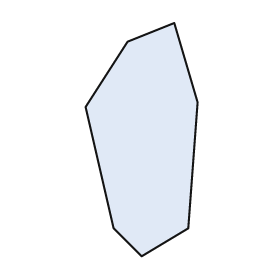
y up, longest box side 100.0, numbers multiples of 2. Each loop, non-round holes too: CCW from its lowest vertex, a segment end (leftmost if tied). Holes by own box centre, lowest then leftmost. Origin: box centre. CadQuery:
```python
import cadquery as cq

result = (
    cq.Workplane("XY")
    .moveTo(0.0, -50.0)
    .lineTo(20.0, -38.0)
    .lineTo(24.0, 16.0)
    .lineTo(14.0, 50.0)
    .lineTo(-6.0, 42.0)
    .lineTo(-24.0, 14.0)
    .lineTo(-12.0, -38.0)
    .close()
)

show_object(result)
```